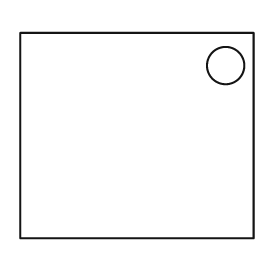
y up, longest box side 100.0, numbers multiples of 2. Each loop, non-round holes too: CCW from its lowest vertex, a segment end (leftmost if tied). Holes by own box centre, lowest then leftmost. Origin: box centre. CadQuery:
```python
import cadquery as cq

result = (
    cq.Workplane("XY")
    .moveTo(-50.0, -44.0)
    .lineTo(50.0, -44.0)
    .lineTo(50.0, 44.0)
    .lineTo(-50.0, 44.0)
    .close()
    .moveTo(38.0, 30.0)
    .circle(8.0)
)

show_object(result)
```